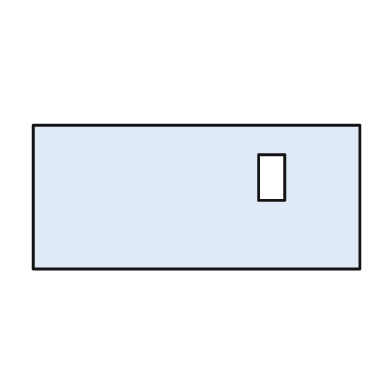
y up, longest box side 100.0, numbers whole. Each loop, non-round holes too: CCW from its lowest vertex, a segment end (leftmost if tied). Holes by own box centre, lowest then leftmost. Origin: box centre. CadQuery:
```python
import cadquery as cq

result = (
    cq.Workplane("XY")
    .moveTo(-50.0, -22.0)
    .lineTo(50.0, -22.0)
    .lineTo(50.0, 22.0)
    .lineTo(-50.0, 22.0)
    .close()
    .moveTo(19.0, -1.0)
    .lineTo(27.0, -1.0)
    .lineTo(27.0, 13.0)
    .lineTo(19.0, 13.0)
    .close()
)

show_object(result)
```